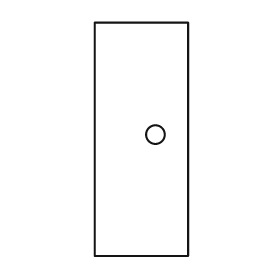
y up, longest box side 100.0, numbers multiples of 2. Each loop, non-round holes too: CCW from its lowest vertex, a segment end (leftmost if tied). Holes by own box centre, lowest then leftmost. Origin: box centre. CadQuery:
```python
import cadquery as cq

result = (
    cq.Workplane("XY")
    .moveTo(-20.0, -50.0)
    .lineTo(20.0, -50.0)
    .lineTo(20.0, 50.0)
    .lineTo(-20.0, 50.0)
    .close()
    .moveTo(6.0, 2.0)
    .circle(4.0)
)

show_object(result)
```